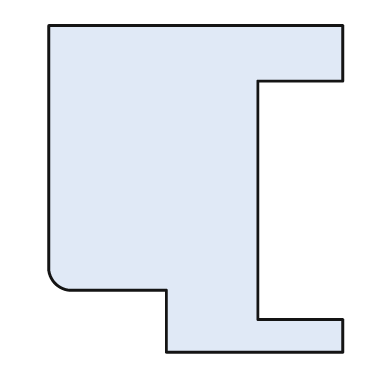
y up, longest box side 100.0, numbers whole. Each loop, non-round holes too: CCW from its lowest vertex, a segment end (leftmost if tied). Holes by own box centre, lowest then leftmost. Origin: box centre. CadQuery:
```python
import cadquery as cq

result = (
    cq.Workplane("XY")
    .moveTo(-9.0, -50.0)
    .lineTo(45.0, -50.0)
    .lineTo(45.0, -40.0)
    .lineTo(19.0, -40.0)
    .lineTo(19.0, 33.0)
    .lineTo(45.0, 33.0)
    .lineTo(45.0, 50.0)
    .lineTo(-45.0, 50.0)
    .lineTo(-45.0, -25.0)
    .threePointArc((-43.0, -29.0), (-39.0, -31.0))
    .lineTo(-9.0, -31.0)
    .close()
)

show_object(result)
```